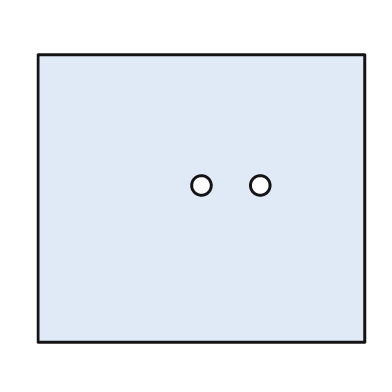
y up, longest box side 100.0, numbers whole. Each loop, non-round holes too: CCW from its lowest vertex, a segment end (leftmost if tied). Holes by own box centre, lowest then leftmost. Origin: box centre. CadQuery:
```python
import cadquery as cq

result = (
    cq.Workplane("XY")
    .moveTo(-50.0, -44.0)
    .lineTo(50.0, -44.0)
    .lineTo(50.0, 44.0)
    .lineTo(-50.0, 44.0)
    .close()
    .moveTo(0.0, 4.0)
    .circle(3.0)
    .moveTo(18.0, 4.0)
    .circle(3.0)
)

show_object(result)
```